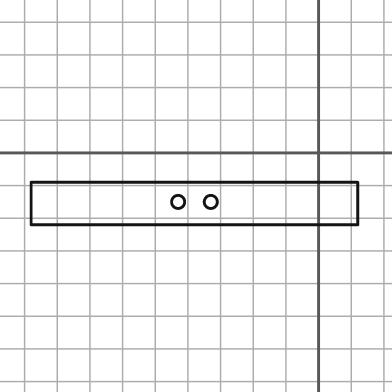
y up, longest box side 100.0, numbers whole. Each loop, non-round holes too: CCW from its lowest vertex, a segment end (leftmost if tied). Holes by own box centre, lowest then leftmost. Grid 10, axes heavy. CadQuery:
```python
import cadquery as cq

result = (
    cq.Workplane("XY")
    .moveTo(-88.0, -22.0)
    .lineTo(12.0, -22.0)
    .lineTo(12.0, -9.0)
    .lineTo(-88.0, -9.0)
    .close()
    .moveTo(-43.0, -15.0)
    .circle(2.0)
    .moveTo(-33.0, -15.0)
    .circle(2.0)
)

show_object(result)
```